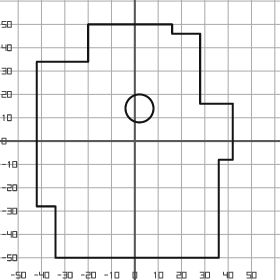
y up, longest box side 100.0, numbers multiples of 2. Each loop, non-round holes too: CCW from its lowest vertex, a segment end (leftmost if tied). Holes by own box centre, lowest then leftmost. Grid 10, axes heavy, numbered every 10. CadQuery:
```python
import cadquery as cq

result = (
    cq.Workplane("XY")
    .moveTo(-34.0, -50.0)
    .lineTo(36.0, -50.0)
    .lineTo(36.0, -8.0)
    .lineTo(42.0, -8.0)
    .lineTo(42.0, 16.0)
    .lineTo(28.0, 16.0)
    .lineTo(28.0, 46.0)
    .lineTo(16.0, 46.0)
    .lineTo(16.0, 50.0)
    .lineTo(-20.0, 50.0)
    .lineTo(-20.0, 34.0)
    .lineTo(-42.0, 34.0)
    .lineTo(-42.0, -28.0)
    .lineTo(-34.0, -28.0)
    .close()
    .moveTo(2.0, 14.0)
    .circle(6.0)
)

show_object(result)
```